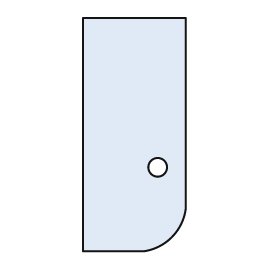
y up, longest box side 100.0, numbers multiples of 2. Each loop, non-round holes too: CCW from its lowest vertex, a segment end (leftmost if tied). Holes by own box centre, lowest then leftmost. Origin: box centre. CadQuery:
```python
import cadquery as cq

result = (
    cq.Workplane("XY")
    .moveTo(-22.0, -50.0)
    .lineTo(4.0, -50.0)
    .threePointArc((16.0, -44.0), (22.0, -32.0))
    .lineTo(22.0, 50.0)
    .lineTo(-22.0, 50.0)
    .close()
    .moveTo(10.0, -14.0)
    .circle(4.0)
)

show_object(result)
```